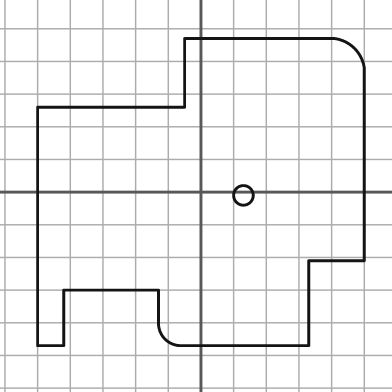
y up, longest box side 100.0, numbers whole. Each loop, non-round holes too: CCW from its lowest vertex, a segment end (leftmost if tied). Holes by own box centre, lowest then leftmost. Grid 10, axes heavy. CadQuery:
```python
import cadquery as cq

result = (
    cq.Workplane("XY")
    .moveTo(-50.0, -47.0)
    .lineTo(-42.0, -47.0)
    .lineTo(-42.0, -30.0)
    .lineTo(-13.0, -30.0)
    .lineTo(-13.0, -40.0)
    .threePointArc((-11.0, -45.0), (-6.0, -47.0))
    .lineTo(33.0, -47.0)
    .lineTo(33.0, -21.0)
    .lineTo(50.0, -21.0)
    .lineTo(50.0, 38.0)
    .threePointArc((47.0, 44.0), (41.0, 47.0))
    .lineTo(-5.0, 47.0)
    .lineTo(-5.0, 26.0)
    .lineTo(-50.0, 26.0)
    .close()
    .moveTo(13.0, -1.0)
    .circle(3.0)
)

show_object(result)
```